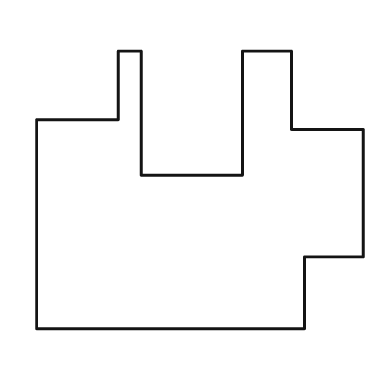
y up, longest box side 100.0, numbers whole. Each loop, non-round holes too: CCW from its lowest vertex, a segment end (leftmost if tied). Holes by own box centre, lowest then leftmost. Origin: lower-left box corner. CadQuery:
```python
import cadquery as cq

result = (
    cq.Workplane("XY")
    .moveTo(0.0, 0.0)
    .lineTo(82.0, 0.0)
    .lineTo(82.0, 22.0)
    .lineTo(100.0, 22.0)
    .lineTo(100.0, 61.0)
    .lineTo(78.0, 61.0)
    .lineTo(78.0, 85.0)
    .lineTo(63.0, 85.0)
    .lineTo(63.0, 47.0)
    .lineTo(32.0, 47.0)
    .lineTo(32.0, 85.0)
    .lineTo(25.0, 85.0)
    .lineTo(25.0, 64.0)
    .lineTo(0.0, 64.0)
    .close()
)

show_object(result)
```